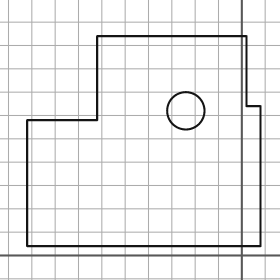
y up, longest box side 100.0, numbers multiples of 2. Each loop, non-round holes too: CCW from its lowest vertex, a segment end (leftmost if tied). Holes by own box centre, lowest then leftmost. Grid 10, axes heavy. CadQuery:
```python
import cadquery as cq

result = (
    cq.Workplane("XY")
    .moveTo(-92.0, 4.0)
    .lineTo(8.0, 4.0)
    .lineTo(8.0, 64.0)
    .lineTo(2.0, 64.0)
    .lineTo(2.0, 94.0)
    .lineTo(-62.0, 94.0)
    .lineTo(-62.0, 58.0)
    .lineTo(-92.0, 58.0)
    .close()
    .moveTo(-24.0, 62.0)
    .circle(8.0)
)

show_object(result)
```